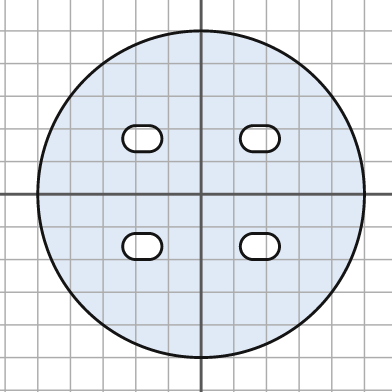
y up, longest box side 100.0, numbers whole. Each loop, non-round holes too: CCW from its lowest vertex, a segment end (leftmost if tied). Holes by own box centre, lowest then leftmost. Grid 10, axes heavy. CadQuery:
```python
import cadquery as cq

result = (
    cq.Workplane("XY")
    .moveTo(0.0, 0.0)
    .circle(50.0)
    .moveTo(-20.0, -20.0)
    .lineTo(-16.0, -20.0)
    .threePointArc((-12.0, -16.0), (-16.0, -12.0))
    .lineTo(-20.0, -12.0)
    .threePointArc((-24.0, -16.0), (-20.0, -20.0))
    .close()
    .moveTo(16.0, -20.0)
    .lineTo(20.0, -20.0)
    .threePointArc((24.0, -16.0), (20.0, -12.0))
    .lineTo(16.0, -12.0)
    .threePointArc((12.0, -16.0), (16.0, -20.0))
    .close()
    .moveTo(-20.0, 13.0)
    .lineTo(-16.0, 13.0)
    .threePointArc((-12.0, 17.0), (-16.0, 21.0))
    .lineTo(-20.0, 21.0)
    .threePointArc((-24.0, 17.0), (-20.0, 13.0))
    .close()
    .moveTo(16.0, 13.0)
    .lineTo(20.0, 13.0)
    .threePointArc((24.0, 17.0), (20.0, 21.0))
    .lineTo(16.0, 21.0)
    .threePointArc((12.0, 17.0), (16.0, 13.0))
    .close()
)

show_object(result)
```